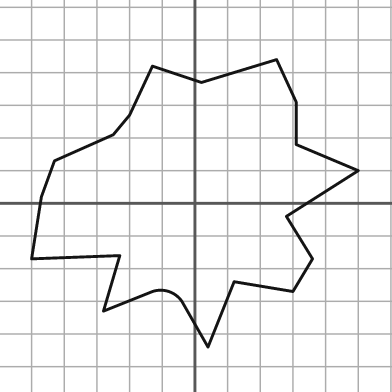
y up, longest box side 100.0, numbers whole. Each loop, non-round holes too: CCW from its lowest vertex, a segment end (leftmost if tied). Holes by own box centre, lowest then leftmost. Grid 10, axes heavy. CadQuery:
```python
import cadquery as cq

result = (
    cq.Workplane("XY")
    .moveTo(4.0, -44.0)
    .lineTo(12.0, -24.0)
    .lineTo(30.0, -27.0)
    .lineTo(36.0, -17.0)
    .lineTo(28.0, -4.0)
    .lineTo(50.0, 10.0)
    .lineTo(31.0, 18.0)
    .lineTo(31.0, 31.0)
    .lineTo(25.0, 44.0)
    .lineTo(2.0, 37.0)
    .lineTo(-13.0, 42.0)
    .lineTo(-20.0, 27.0)
    .lineTo(-25.0, 21.0)
    .lineTo(-43.0, 13.0)
    .lineTo(-47.0, 2.0)
    .lineTo(-50.0, -17.0)
    .lineTo(-23.0, -16.0)
    .lineTo(-28.0, -33.0)
    .lineTo(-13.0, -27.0)
    .threePointArc((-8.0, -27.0), (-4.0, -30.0))
    .close()
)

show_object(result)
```